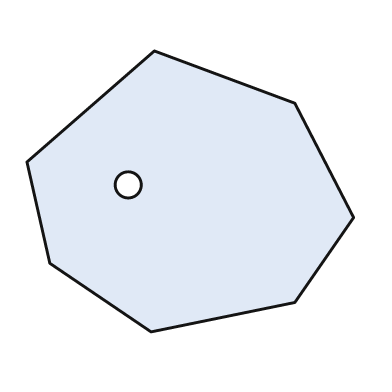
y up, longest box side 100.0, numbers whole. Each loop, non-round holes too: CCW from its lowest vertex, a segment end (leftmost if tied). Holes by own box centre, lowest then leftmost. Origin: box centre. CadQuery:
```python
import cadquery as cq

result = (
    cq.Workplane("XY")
    .moveTo(-12.0, -43.0)
    .lineTo(32.0, -34.0)
    .lineTo(50.0, -8.0)
    .lineTo(32.0, 27.0)
    .lineTo(-11.0, 43.0)
    .lineTo(-50.0, 9.0)
    .lineTo(-43.0, -22.0)
    .close()
    .moveTo(-19.0, 2.0)
    .circle(4.0)
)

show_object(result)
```